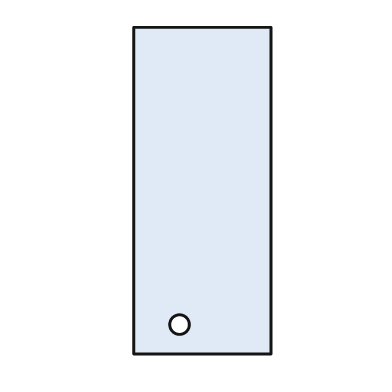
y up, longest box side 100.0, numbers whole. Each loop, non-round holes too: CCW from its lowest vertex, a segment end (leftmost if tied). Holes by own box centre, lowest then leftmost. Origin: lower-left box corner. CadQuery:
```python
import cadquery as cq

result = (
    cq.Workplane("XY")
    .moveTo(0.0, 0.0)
    .lineTo(42.0, 0.0)
    .lineTo(42.0, 100.0)
    .lineTo(0.0, 100.0)
    .close()
    .moveTo(14.0, 9.0)
    .circle(3.0)
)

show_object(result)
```